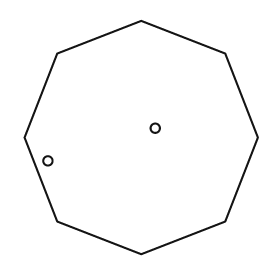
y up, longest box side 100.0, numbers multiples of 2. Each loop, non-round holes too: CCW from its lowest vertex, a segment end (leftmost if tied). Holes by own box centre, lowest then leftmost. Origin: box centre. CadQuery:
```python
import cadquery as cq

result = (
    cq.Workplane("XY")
    .moveTo(0.0, -50.0)
    .lineTo(36.0, -36.0)
    .lineTo(50.0, 0.0)
    .lineTo(36.0, 36.0)
    .lineTo(0.0, 50.0)
    .lineTo(-36.0, 36.0)
    .lineTo(-50.0, 0.0)
    .lineTo(-36.0, -36.0)
    .close()
    .moveTo(-40.0, -10.0)
    .circle(2.0)
    .moveTo(6.0, 4.0)
    .circle(2.0)
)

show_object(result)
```